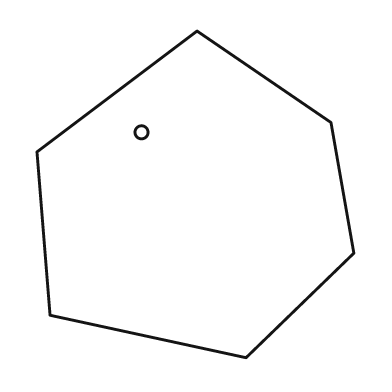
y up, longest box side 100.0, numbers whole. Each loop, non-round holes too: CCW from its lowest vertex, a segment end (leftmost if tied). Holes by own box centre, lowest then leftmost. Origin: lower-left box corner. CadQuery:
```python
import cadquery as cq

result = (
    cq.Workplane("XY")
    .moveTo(64.0, 0.0)
    .lineTo(97.0, 32.0)
    .lineTo(90.0, 72.0)
    .lineTo(49.0, 100.0)
    .lineTo(0.0, 63.0)
    .lineTo(4.0, 13.0)
    .close()
    .moveTo(32.0, 69.0)
    .circle(2.0)
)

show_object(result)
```